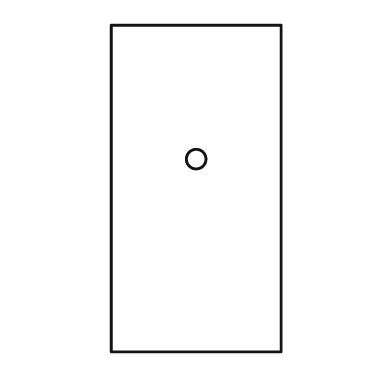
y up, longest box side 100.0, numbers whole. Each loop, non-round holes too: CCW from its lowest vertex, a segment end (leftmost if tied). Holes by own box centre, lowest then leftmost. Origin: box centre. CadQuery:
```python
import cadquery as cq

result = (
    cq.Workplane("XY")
    .moveTo(-26.0, -50.0)
    .lineTo(26.0, -50.0)
    .lineTo(26.0, 50.0)
    .lineTo(-26.0, 50.0)
    .close()
    .moveTo(0.0, 9.0)
    .circle(3.0)
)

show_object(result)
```